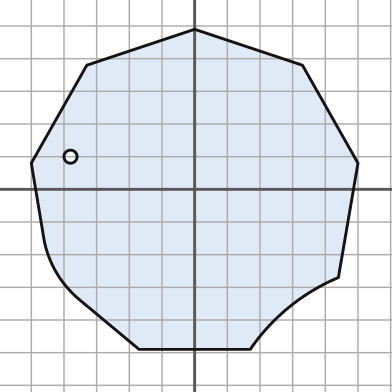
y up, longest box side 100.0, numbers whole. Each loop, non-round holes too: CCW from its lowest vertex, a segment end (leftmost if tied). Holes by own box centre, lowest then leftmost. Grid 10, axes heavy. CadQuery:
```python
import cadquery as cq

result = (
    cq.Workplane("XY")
    .moveTo(-17.0, -49.0)
    .lineTo(17.0, -49.0)
    .threePointArc((29.0, -36.0), (44.0, -27.0))
    .lineTo(50.0, 8.0)
    .lineTo(33.0, 38.0)
    .lineTo(0.0, 49.0)
    .lineTo(-33.0, 38.0)
    .lineTo(-50.0, 8.0)
    .lineTo(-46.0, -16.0)
    .threePointArc((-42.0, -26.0), (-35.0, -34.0))
    .close()
    .moveTo(-38.0, 10.0)
    .circle(2.0)
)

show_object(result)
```